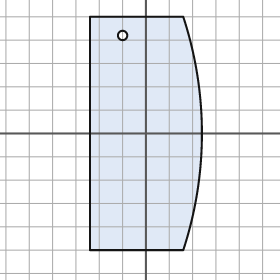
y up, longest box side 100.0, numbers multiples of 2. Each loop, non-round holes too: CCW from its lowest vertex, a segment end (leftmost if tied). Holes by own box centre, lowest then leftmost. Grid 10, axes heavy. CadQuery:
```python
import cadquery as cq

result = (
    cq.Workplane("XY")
    .moveTo(-24.0, -50.0)
    .lineTo(16.0, -50.0)
    .threePointArc((24.0, 0.0), (16.0, 50.0))
    .lineTo(-24.0, 50.0)
    .close()
    .moveTo(-10.0, 42.0)
    .circle(2.0)
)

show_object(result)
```